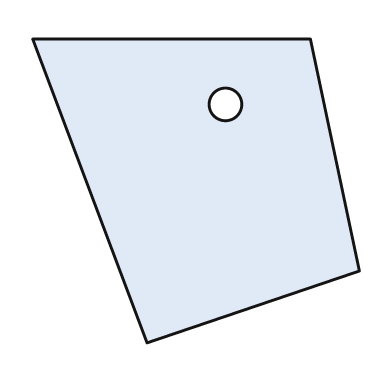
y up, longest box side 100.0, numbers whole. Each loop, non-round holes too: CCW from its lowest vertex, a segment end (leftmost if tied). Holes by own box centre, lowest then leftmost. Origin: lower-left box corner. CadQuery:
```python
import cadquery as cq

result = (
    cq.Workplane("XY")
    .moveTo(35.0, 0.0)
    .lineTo(100.0, 22.0)
    .lineTo(85.0, 93.0)
    .lineTo(0.0, 93.0)
    .close()
    .moveTo(59.0, 73.0)
    .circle(5.0)
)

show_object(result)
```